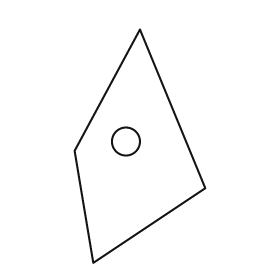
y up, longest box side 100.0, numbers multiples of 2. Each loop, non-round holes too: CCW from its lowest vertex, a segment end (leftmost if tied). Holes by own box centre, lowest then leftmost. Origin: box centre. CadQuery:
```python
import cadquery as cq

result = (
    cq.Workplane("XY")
    .moveTo(-20.0, -50.0)
    .lineTo(28.0, -18.0)
    .lineTo(0.0, 50.0)
    .lineTo(-28.0, -2.0)
    .close()
    .moveTo(-6.0, 2.0)
    .circle(6.0)
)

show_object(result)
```